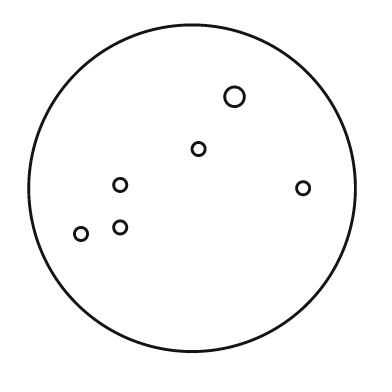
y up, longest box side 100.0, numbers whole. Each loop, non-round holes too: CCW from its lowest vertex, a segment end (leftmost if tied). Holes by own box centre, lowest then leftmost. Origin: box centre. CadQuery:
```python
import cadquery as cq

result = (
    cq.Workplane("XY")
    .moveTo(0.0, 0.0)
    .circle(50.0)
    .moveTo(-34.0, -14.0)
    .circle(2.0)
    .moveTo(-22.0, -12.0)
    .circle(2.0)
    .moveTo(34.0, 0.0)
    .circle(2.0)
    .moveTo(-22.0, 1.0)
    .circle(2.0)
    .moveTo(2.0, 12.0)
    .circle(2.0)
    .moveTo(13.0, 28.0)
    .circle(3.0)
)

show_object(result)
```